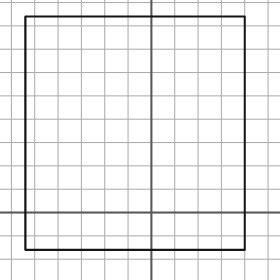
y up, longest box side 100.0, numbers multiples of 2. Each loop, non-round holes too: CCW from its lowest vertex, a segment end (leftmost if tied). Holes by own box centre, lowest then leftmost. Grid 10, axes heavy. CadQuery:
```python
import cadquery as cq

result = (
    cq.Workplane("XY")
    .moveTo(-54.0, -16.0)
    .lineTo(40.0, -16.0)
    .lineTo(40.0, 84.0)
    .lineTo(-54.0, 84.0)
    .close()
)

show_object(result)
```